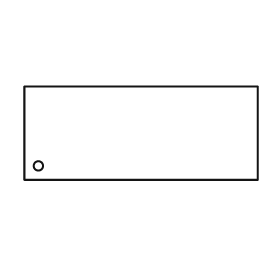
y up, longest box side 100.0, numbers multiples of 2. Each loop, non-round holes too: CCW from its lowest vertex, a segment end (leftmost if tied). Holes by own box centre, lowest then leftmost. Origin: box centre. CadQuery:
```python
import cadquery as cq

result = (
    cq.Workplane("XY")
    .moveTo(-50.0, -20.0)
    .lineTo(50.0, -20.0)
    .lineTo(50.0, 20.0)
    .lineTo(-50.0, 20.0)
    .close()
    .moveTo(-44.0, -14.0)
    .circle(2.0)
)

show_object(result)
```